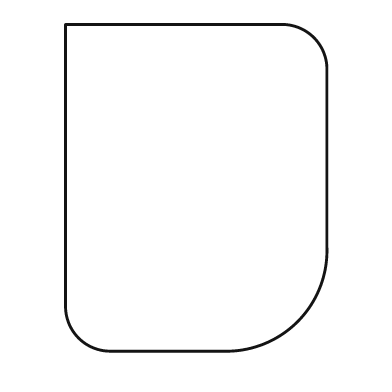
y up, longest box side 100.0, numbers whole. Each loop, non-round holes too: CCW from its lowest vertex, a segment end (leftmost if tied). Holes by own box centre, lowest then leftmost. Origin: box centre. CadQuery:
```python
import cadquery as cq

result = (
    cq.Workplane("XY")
    .moveTo(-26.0, -50.0)
    .lineTo(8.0, -50.0)
    .threePointArc((31.0, -41.0), (40.0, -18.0))
    .lineTo(40.0, 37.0)
    .threePointArc((36.0, 46.0), (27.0, 50.0))
    .lineTo(-40.0, 50.0)
    .lineTo(-40.0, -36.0)
    .threePointArc((-36.0, -46.0), (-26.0, -50.0))
    .close()
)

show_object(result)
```